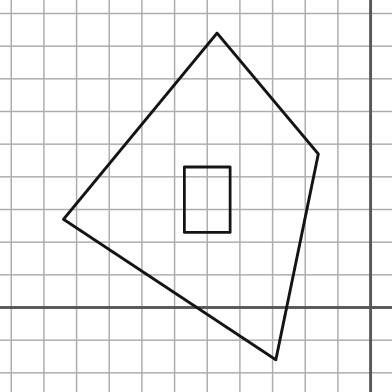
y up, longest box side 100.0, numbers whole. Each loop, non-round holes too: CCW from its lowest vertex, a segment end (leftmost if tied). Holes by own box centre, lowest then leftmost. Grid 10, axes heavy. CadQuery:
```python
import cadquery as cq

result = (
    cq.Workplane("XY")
    .moveTo(-29.0, -16.0)
    .lineTo(-16.0, 47.0)
    .lineTo(-47.0, 84.0)
    .lineTo(-94.0, 27.0)
    .close()
    .moveTo(-57.0, 23.0)
    .lineTo(-43.0, 23.0)
    .lineTo(-43.0, 43.0)
    .lineTo(-57.0, 43.0)
    .close()
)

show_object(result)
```